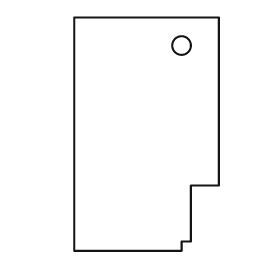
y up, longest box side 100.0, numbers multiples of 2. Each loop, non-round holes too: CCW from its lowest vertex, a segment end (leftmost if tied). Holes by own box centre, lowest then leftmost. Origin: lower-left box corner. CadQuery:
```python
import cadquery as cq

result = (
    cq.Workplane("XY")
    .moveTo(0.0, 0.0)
    .lineTo(46.0, 0.0)
    .lineTo(46.0, 4.0)
    .lineTo(50.0, 4.0)
    .lineTo(50.0, 28.0)
    .lineTo(62.0, 28.0)
    .lineTo(62.0, 100.0)
    .lineTo(0.0, 100.0)
    .close()
    .moveTo(46.0, 88.0)
    .circle(4.0)
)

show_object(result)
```